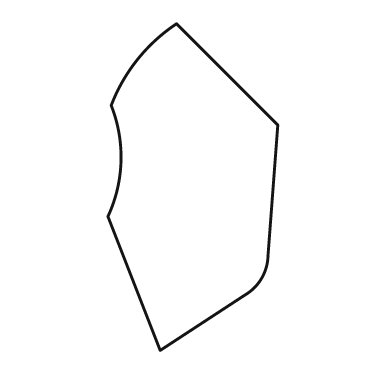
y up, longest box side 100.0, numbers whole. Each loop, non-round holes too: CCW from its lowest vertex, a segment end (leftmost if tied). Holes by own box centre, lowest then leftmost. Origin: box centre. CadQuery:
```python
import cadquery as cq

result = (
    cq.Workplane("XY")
    .moveTo(-10.0, -50.0)
    .lineTo(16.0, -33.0)
    .threePointArc((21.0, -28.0), (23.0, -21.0))
    .lineTo(26.0, 19.0)
    .lineTo(-5.0, 50.0)
    .threePointArc((-17.0, 39.0), (-25.0, 25.0))
    .threePointArc((-22.0, 8.0), (-26.0, -9.0))
    .close()
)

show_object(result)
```